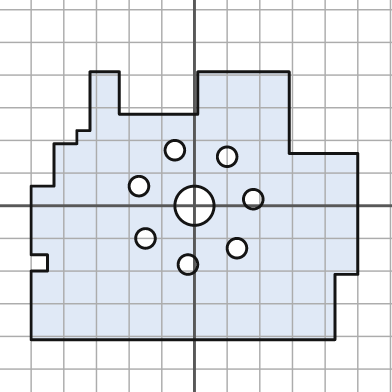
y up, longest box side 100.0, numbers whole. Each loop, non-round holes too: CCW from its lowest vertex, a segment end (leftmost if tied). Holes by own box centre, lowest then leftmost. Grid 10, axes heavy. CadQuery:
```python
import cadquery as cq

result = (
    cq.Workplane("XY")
    .moveTo(-50.0, -41.0)
    .lineTo(43.0, -41.0)
    .lineTo(43.0, -21.0)
    .lineTo(50.0, -21.0)
    .lineTo(50.0, 16.0)
    .lineTo(29.0, 16.0)
    .lineTo(29.0, 41.0)
    .lineTo(1.0, 41.0)
    .lineTo(1.0, 28.0)
    .lineTo(-23.0, 28.0)
    .lineTo(-23.0, 41.0)
    .lineTo(-32.0, 41.0)
    .lineTo(-32.0, 23.0)
    .lineTo(-36.0, 23.0)
    .lineTo(-36.0, 19.0)
    .lineTo(-43.0, 19.0)
    .lineTo(-43.0, 6.0)
    .lineTo(-50.0, 6.0)
    .lineTo(-50.0, -15.0)
    .lineTo(-45.0, -15.0)
    .lineTo(-45.0, -20.0)
    .lineTo(-50.0, -20.0)
    .close()
    .moveTo(-2.0, -18.0)
    .circle(3.0)
    .moveTo(13.0, -13.0)
    .circle(3.0)
    .moveTo(-15.0, -10.0)
    .circle(3.0)
    .moveTo(0.0, 0.0)
    .circle(6.0)
    .moveTo(18.0, 2.0)
    .circle(3.0)
    .moveTo(-17.0, 6.0)
    .circle(3.0)
    .moveTo(10.0, 15.0)
    .circle(3.0)
    .moveTo(-6.0, 17.0)
    .circle(3.0)
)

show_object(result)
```